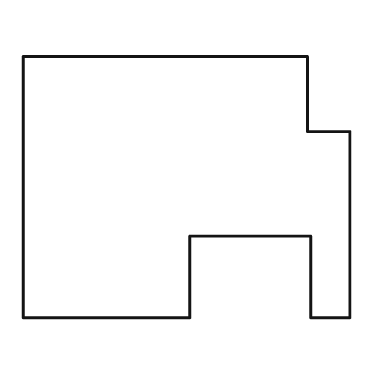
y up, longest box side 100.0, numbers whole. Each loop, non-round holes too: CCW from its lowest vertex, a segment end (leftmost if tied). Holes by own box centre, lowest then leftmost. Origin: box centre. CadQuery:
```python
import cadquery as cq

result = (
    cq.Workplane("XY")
    .moveTo(-50.0, -40.0)
    .lineTo(1.0, -40.0)
    .lineTo(1.0, -15.0)
    .lineTo(38.0, -15.0)
    .lineTo(38.0, -40.0)
    .lineTo(50.0, -40.0)
    .lineTo(50.0, 17.0)
    .lineTo(37.0, 17.0)
    .lineTo(37.0, 40.0)
    .lineTo(-50.0, 40.0)
    .close()
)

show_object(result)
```